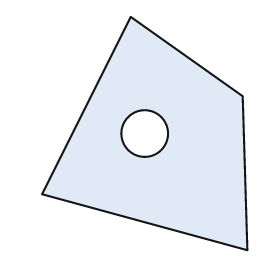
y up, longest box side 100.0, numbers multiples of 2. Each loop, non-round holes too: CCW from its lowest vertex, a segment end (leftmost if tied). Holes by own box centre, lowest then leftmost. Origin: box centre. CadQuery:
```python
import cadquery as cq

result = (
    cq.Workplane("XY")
    .moveTo(44.0, -50.0)
    .lineTo(42.0, 16.0)
    .lineTo(-6.0, 50.0)
    .lineTo(-44.0, -26.0)
    .close()
    .moveTo(0.0, 0.0)
    .circle(10.0)
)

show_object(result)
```